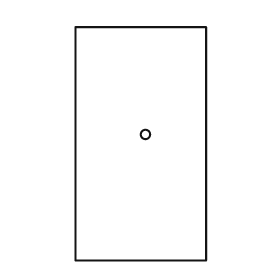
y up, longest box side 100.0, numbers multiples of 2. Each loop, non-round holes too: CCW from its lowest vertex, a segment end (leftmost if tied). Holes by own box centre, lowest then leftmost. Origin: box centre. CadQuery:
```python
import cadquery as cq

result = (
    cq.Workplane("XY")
    .moveTo(-28.0, -50.0)
    .lineTo(28.0, -50.0)
    .lineTo(28.0, 50.0)
    .lineTo(-28.0, 50.0)
    .close()
    .moveTo(2.0, 4.0)
    .circle(2.0)
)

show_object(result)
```